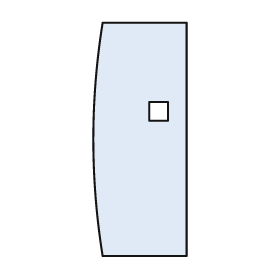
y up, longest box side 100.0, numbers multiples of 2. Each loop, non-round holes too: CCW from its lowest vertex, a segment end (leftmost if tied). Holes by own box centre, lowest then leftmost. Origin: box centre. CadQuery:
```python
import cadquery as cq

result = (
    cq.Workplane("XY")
    .moveTo(-16.0, -50.0)
    .lineTo(20.0, -50.0)
    .lineTo(20.0, 50.0)
    .lineTo(-16.0, 50.0)
    .threePointArc((-20.0, 0.0), (-16.0, -50.0))
    .close()
    .moveTo(4.0, 8.0)
    .lineTo(12.0, 8.0)
    .lineTo(12.0, 16.0)
    .lineTo(4.0, 16.0)
    .close()
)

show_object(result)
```